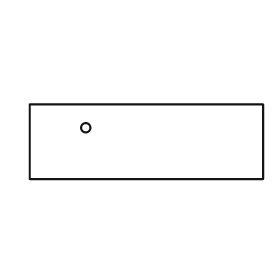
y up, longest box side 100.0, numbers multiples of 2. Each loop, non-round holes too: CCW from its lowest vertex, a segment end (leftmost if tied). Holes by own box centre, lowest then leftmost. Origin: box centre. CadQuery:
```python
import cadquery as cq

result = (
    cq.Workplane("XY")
    .moveTo(-50.0, -16.0)
    .lineTo(50.0, -16.0)
    .lineTo(50.0, 16.0)
    .lineTo(-50.0, 16.0)
    .close()
    .moveTo(-26.0, 6.0)
    .circle(2.0)
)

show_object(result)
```